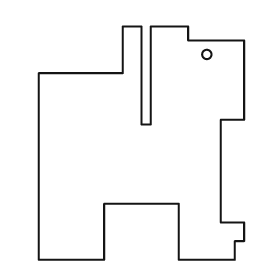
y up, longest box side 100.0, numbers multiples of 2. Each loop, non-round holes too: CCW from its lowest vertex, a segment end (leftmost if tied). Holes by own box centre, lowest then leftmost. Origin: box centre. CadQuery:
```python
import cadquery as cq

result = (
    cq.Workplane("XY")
    .moveTo(-44.0, -50.0)
    .lineTo(-16.0, -50.0)
    .lineTo(-16.0, -26.0)
    .lineTo(16.0, -26.0)
    .lineTo(16.0, -50.0)
    .lineTo(40.0, -50.0)
    .lineTo(40.0, -42.0)
    .lineTo(44.0, -42.0)
    .lineTo(44.0, -34.0)
    .lineTo(34.0, -34.0)
    .lineTo(34.0, 10.0)
    .lineTo(44.0, 10.0)
    .lineTo(44.0, 44.0)
    .lineTo(20.0, 44.0)
    .lineTo(20.0, 50.0)
    .lineTo(4.0, 50.0)
    .lineTo(4.0, 8.0)
    .lineTo(0.0, 8.0)
    .lineTo(0.0, 50.0)
    .lineTo(-8.0, 50.0)
    .lineTo(-8.0, 30.0)
    .lineTo(-44.0, 30.0)
    .close()
    .moveTo(28.0, 38.0)
    .circle(2.0)
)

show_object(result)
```